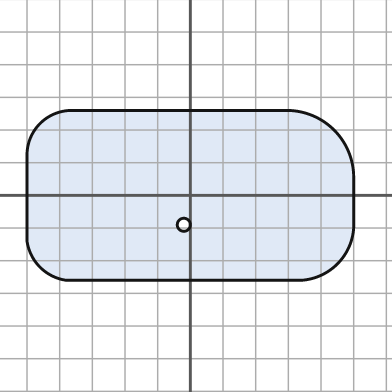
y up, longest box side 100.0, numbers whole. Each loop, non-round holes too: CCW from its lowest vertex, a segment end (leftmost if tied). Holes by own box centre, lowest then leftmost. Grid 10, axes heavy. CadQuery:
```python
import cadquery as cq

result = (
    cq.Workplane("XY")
    .moveTo(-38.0, -26.0)
    .lineTo(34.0, -26.0)
    .threePointArc((45.0, -21.0), (50.0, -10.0))
    .lineTo(50.0, 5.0)
    .threePointArc((44.0, 20.0), (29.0, 26.0))
    .lineTo(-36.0, 26.0)
    .threePointArc((-46.0, 22.0), (-50.0, 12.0))
    .lineTo(-50.0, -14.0)
    .threePointArc((-46.0, -22.0), (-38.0, -26.0))
    .close()
    .moveTo(-2.0, -9.0)
    .circle(2.0)
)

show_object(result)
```